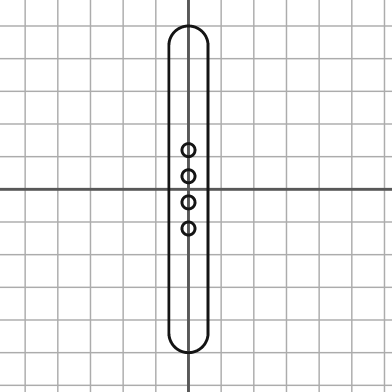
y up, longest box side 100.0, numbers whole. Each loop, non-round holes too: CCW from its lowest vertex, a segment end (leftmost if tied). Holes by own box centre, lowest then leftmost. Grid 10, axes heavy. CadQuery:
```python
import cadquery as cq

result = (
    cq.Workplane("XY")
    .moveTo(-6.0, -44.0)
    .threePointArc((0.0, -50.0), (6.0, -44.0))
    .lineTo(6.0, 44.0)
    .threePointArc((0.0, 50.0), (-6.0, 44.0))
    .close()
    .moveTo(0.0, -12.0)
    .circle(2.0)
    .moveTo(0.0, -4.0)
    .circle(2.0)
    .moveTo(0.0, 4.0)
    .circle(2.0)
    .moveTo(0.0, 12.0)
    .circle(2.0)
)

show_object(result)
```